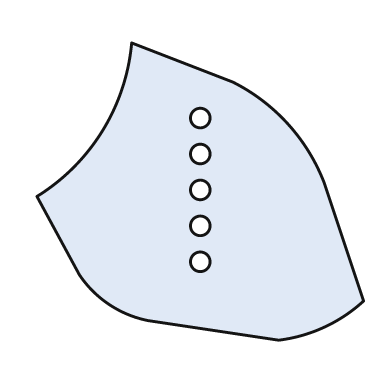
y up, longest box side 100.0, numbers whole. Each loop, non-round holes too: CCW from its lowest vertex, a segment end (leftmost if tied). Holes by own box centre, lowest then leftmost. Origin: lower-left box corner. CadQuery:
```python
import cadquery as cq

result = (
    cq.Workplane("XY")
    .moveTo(74.0, 0.0)
    .threePointArc((88.0, 4.0), (100.0, 12.0))
    .lineTo(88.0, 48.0)
    .threePointArc((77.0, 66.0), (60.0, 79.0))
    .lineTo(29.0, 91.0)
    .threePointArc((20.0, 64.0), (0.0, 44.0))
    .lineTo(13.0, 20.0)
    .threePointArc((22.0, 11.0), (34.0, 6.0))
    .close()
    .moveTo(50.0, 24.0)
    .circle(3.0)
    .moveTo(50.0, 35.0)
    .circle(3.0)
    .moveTo(50.0, 46.0)
    .circle(3.0)
    .moveTo(50.0, 57.0)
    .circle(3.0)
    .moveTo(50.0, 68.0)
    .circle(3.0)
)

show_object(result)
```